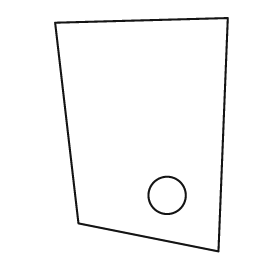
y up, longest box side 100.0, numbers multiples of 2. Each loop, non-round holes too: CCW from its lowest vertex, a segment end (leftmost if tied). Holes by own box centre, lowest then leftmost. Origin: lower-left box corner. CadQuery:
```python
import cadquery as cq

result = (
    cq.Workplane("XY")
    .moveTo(70.0, 0.0)
    .lineTo(74.0, 100.0)
    .lineTo(0.0, 98.0)
    .lineTo(10.0, 12.0)
    .close()
    .moveTo(48.0, 24.0)
    .circle(8.0)
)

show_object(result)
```